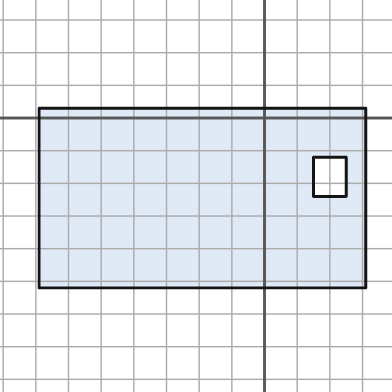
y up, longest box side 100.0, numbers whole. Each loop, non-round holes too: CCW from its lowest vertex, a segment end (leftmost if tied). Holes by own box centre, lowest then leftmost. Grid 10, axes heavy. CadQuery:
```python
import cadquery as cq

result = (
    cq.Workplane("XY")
    .moveTo(-69.0, -52.0)
    .lineTo(31.0, -52.0)
    .lineTo(31.0, 3.0)
    .lineTo(-69.0, 3.0)
    .close()
    .moveTo(15.0, -24.0)
    .lineTo(25.0, -24.0)
    .lineTo(25.0, -12.0)
    .lineTo(15.0, -12.0)
    .close()
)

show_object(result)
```